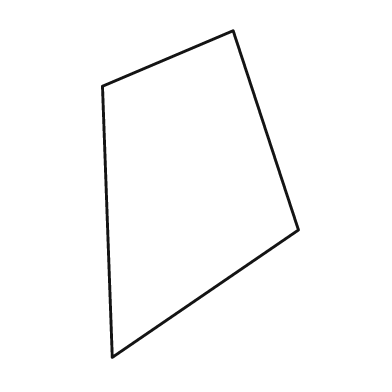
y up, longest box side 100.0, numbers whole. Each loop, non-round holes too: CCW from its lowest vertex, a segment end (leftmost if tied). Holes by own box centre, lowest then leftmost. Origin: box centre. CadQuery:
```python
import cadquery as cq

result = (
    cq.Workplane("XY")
    .moveTo(-27.0, -50.0)
    .lineTo(30.0, -11.0)
    .lineTo(10.0, 50.0)
    .lineTo(-30.0, 33.0)
    .close()
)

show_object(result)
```